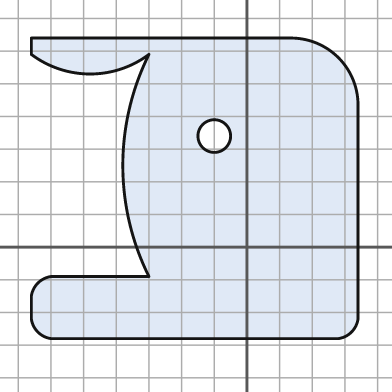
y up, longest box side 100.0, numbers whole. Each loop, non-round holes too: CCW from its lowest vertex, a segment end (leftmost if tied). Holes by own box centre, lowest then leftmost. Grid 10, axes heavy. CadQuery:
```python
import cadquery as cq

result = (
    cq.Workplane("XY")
    .moveTo(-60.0, -28.0)
    .lineTo(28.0, -28.0)
    .threePointArc((32.0, -26.0), (34.0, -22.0))
    .lineTo(34.0, 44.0)
    .threePointArc((28.0, 58.0), (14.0, 64.0))
    .lineTo(-66.0, 64.0)
    .lineTo(-66.0, 59.0)
    .threePointArc((-48.0, 53.0), (-30.0, 59.0))
    .threePointArc((-38.0, 25.0), (-30.0, -9.0))
    .lineTo(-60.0, -9.0)
    .threePointArc((-64.0, -11.0), (-66.0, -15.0))
    .lineTo(-66.0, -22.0)
    .threePointArc((-64.0, -26.0), (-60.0, -28.0))
    .close()
    .moveTo(-10.0, 34.0)
    .circle(5.0)
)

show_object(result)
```